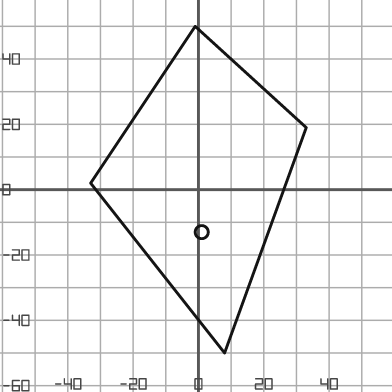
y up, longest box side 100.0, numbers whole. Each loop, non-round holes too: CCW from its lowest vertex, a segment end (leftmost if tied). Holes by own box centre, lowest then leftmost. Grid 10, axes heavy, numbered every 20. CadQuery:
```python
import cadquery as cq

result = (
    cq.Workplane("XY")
    .moveTo(8.0, -50.0)
    .lineTo(33.0, 19.0)
    .lineTo(-1.0, 50.0)
    .lineTo(-33.0, 2.0)
    .close()
    .moveTo(1.0, -13.0)
    .circle(2.0)
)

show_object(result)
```